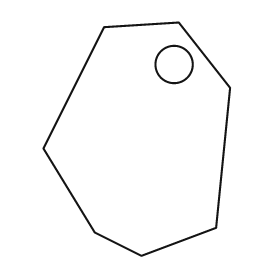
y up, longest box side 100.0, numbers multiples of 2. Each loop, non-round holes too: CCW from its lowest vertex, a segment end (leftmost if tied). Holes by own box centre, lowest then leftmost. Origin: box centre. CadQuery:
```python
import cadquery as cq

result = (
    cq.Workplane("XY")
    .moveTo(2.0, -50.0)
    .lineTo(34.0, -38.0)
    .lineTo(40.0, 22.0)
    .lineTo(18.0, 50.0)
    .lineTo(-14.0, 48.0)
    .lineTo(-40.0, -4.0)
    .lineTo(-18.0, -40.0)
    .close()
    .moveTo(16.0, 32.0)
    .circle(8.0)
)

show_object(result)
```